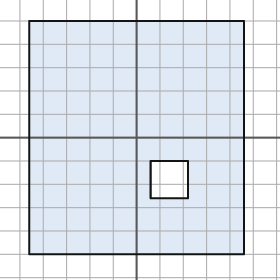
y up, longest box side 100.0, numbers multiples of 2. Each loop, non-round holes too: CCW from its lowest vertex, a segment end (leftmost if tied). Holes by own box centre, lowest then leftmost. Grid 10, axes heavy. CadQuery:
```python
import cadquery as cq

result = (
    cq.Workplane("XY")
    .moveTo(-46.0, -50.0)
    .lineTo(46.0, -50.0)
    .lineTo(46.0, 50.0)
    .lineTo(-46.0, 50.0)
    .close()
    .moveTo(6.0, -26.0)
    .lineTo(22.0, -26.0)
    .lineTo(22.0, -10.0)
    .lineTo(6.0, -10.0)
    .close()
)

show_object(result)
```